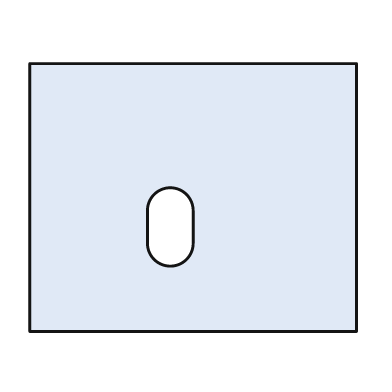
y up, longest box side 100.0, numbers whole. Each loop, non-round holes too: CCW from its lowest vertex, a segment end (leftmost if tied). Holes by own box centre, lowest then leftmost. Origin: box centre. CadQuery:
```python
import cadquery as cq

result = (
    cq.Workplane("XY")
    .moveTo(-50.0, -41.0)
    .lineTo(50.0, -41.0)
    .lineTo(50.0, 41.0)
    .lineTo(-50.0, 41.0)
    .close()
    .moveTo(-14.0, -14.0)
    .threePointArc((-7.0, -21.0), (0.0, -14.0))
    .lineTo(0.0, -4.0)
    .threePointArc((-7.0, 3.0), (-14.0, -4.0))
    .close()
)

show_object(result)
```